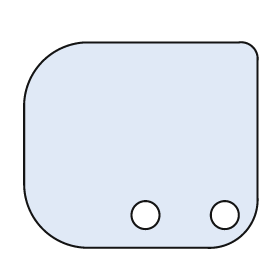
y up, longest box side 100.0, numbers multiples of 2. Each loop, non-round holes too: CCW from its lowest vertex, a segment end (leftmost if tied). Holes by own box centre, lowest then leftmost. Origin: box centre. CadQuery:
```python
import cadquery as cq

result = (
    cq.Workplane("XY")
    .moveTo(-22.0, -44.0)
    .lineTo(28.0, -44.0)
    .threePointArc((44.0, -38.0), (50.0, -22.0))
    .lineTo(50.0, 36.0)
    .threePointArc((48.0, 42.0), (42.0, 44.0))
    .lineTo(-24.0, 44.0)
    .threePointArc((-42.0, 36.0), (-50.0, 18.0))
    .lineTo(-50.0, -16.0)
    .threePointArc((-42.0, -36.0), (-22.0, -44.0))
    .close()
    .moveTo(2.0, -30.0)
    .circle(6.0)
    .moveTo(36.0, -30.0)
    .circle(6.0)
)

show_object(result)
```